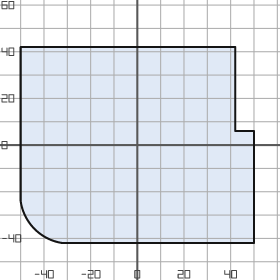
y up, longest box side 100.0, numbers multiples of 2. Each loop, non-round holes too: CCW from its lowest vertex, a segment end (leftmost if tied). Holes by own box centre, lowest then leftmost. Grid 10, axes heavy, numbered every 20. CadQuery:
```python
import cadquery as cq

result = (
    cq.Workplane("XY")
    .moveTo(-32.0, -42.0)
    .lineTo(50.0, -42.0)
    .lineTo(50.0, 6.0)
    .lineTo(42.0, 6.0)
    .lineTo(42.0, 42.0)
    .lineTo(-50.0, 42.0)
    .lineTo(-50.0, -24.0)
    .threePointArc((-44.0, -36.0), (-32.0, -42.0))
    .close()
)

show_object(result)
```